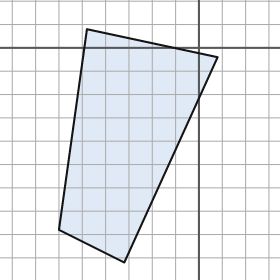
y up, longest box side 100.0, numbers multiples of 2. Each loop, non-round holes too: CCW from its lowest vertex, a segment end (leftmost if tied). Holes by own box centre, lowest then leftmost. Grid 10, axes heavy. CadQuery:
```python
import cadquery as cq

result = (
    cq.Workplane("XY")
    .moveTo(-32.0, -92.0)
    .lineTo(8.0, -4.0)
    .lineTo(-48.0, 8.0)
    .lineTo(-60.0, -78.0)
    .close()
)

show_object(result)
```